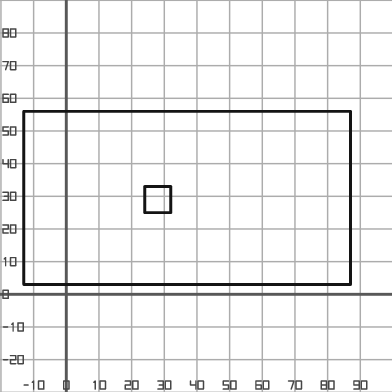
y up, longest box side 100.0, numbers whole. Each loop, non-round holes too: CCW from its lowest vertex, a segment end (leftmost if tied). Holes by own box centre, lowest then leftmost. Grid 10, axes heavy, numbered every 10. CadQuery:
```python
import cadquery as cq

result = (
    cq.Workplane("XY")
    .moveTo(-13.0, 3.0)
    .lineTo(87.0, 3.0)
    .lineTo(87.0, 56.0)
    .lineTo(-13.0, 56.0)
    .close()
    .moveTo(24.0, 25.0)
    .lineTo(32.0, 25.0)
    .lineTo(32.0, 33.0)
    .lineTo(24.0, 33.0)
    .close()
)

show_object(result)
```